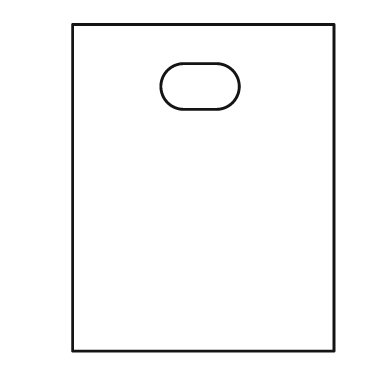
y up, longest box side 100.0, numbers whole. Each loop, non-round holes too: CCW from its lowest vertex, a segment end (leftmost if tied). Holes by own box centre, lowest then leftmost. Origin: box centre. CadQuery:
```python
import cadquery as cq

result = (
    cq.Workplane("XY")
    .moveTo(-40.0, -50.0)
    .lineTo(40.0, -50.0)
    .lineTo(40.0, 50.0)
    .lineTo(-40.0, 50.0)
    .close()
    .moveTo(-6.0, 24.0)
    .lineTo(4.0, 24.0)
    .threePointArc((11.0, 31.0), (4.0, 38.0))
    .lineTo(-6.0, 38.0)
    .threePointArc((-13.0, 31.0), (-6.0, 24.0))
    .close()
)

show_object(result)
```